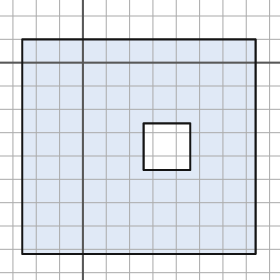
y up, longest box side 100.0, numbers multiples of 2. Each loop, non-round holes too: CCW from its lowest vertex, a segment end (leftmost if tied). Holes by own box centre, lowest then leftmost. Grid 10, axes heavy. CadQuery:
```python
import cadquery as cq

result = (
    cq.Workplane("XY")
    .moveTo(-26.0, -82.0)
    .lineTo(74.0, -82.0)
    .lineTo(74.0, 10.0)
    .lineTo(-26.0, 10.0)
    .close()
    .moveTo(26.0, -46.0)
    .lineTo(46.0, -46.0)
    .lineTo(46.0, -26.0)
    .lineTo(26.0, -26.0)
    .close()
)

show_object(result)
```